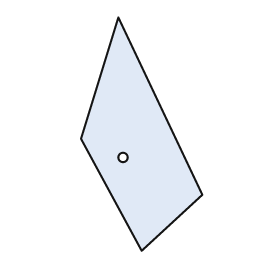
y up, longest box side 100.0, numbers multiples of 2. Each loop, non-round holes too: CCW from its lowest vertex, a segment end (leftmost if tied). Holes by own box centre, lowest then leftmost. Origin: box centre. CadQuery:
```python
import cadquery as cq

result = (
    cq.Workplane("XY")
    .moveTo(0.0, -50.0)
    .lineTo(26.0, -26.0)
    .lineTo(-10.0, 50.0)
    .lineTo(-26.0, -2.0)
    .close()
    .moveTo(-8.0, -10.0)
    .circle(2.0)
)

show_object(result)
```